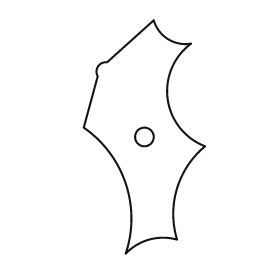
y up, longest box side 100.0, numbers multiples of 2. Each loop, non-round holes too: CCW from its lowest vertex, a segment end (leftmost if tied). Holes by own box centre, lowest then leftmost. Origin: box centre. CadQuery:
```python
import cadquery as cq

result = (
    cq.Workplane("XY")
    .moveTo(-8.0, -50.0)
    .threePointArc((2.0, -44.0), (14.0, -44.0))
    .threePointArc((14.0, -22.0), (26.0, -4.0))
    .threePointArc((10.0, 16.0), (20.0, 40.0))
    .threePointArc((10.0, 42.0), (4.0, 50.0))
    .lineTo(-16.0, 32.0)
    .threePointArc((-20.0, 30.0), (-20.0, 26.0))
    .lineTo(-26.0, 4.0)
    .threePointArc((-8.0, -20.0), (-8.0, -50.0))
    .close()
    .moveTo(0.0, 0.0)
    .circle(4.0)
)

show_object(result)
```